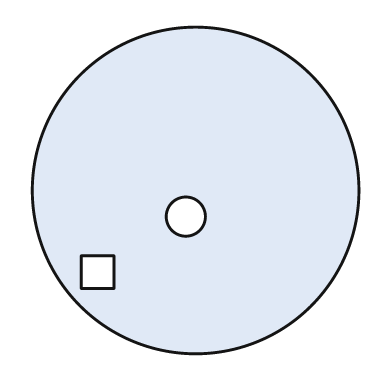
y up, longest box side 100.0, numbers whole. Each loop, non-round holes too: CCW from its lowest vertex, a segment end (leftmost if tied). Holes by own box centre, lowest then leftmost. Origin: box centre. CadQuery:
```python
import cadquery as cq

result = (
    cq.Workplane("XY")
    .moveTo(0.0, 0.0)
    .circle(50.0)
    .moveTo(-35.0, -30.0)
    .lineTo(-25.0, -30.0)
    .lineTo(-25.0, -20.0)
    .lineTo(-35.0, -20.0)
    .close()
    .moveTo(-3.0, -8.0)
    .circle(6.0)
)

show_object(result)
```